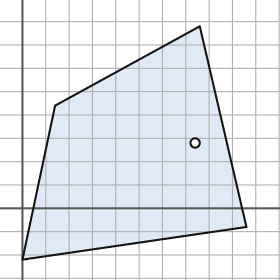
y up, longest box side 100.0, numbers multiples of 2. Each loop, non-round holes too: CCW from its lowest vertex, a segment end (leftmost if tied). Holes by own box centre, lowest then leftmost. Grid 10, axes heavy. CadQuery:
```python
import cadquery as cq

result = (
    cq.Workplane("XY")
    .moveTo(0.0, -22.0)
    .lineTo(96.0, -8.0)
    .lineTo(76.0, 78.0)
    .lineTo(14.0, 44.0)
    .close()
    .moveTo(74.0, 28.0)
    .circle(2.0)
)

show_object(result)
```